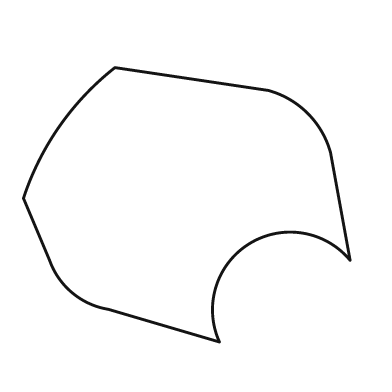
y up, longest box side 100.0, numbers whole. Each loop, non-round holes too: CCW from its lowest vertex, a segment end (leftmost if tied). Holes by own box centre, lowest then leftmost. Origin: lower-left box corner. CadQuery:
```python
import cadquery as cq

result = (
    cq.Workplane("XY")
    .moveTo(60.0, 0.0)
    .threePointArc((69.0, 30.0), (100.0, 25.0))
    .lineTo(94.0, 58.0)
    .threePointArc((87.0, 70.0), (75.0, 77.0))
    .lineTo(28.0, 84.0)
    .threePointArc((11.0, 66.0), (0.0, 44.0))
    .lineTo(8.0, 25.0)
    .threePointArc((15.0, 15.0), (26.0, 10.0))
    .close()
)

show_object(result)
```